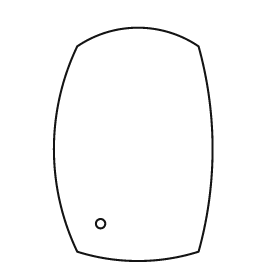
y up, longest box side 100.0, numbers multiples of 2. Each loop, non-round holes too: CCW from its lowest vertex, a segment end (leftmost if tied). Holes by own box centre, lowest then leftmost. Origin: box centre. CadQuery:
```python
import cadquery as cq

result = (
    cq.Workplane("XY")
    .moveTo(-24.0, -46.0)
    .threePointArc((2.0, -50.0), (28.0, -46.0))
    .threePointArc((34.0, -2.0), (28.0, 42.0))
    .threePointArc((2.0, 50.0), (-24.0, 42.0))
    .threePointArc((-34.0, -2.0), (-24.0, -46.0))
    .close()
    .moveTo(-14.0, -34.0)
    .circle(2.0)
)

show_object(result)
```